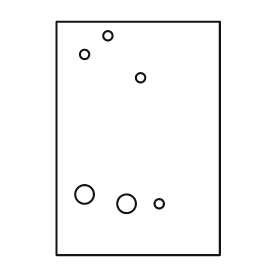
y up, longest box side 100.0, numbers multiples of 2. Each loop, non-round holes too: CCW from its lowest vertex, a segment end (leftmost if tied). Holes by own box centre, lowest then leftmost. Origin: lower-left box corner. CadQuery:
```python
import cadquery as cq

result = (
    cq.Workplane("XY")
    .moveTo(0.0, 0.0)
    .lineTo(70.0, 0.0)
    .lineTo(70.0, 100.0)
    .lineTo(0.0, 100.0)
    .close()
    .moveTo(30.0, 22.0)
    .circle(4.0)
    .moveTo(44.0, 22.0)
    .circle(2.0)
    .moveTo(12.0, 26.0)
    .circle(4.0)
    .moveTo(36.0, 76.0)
    .circle(2.0)
    .moveTo(12.0, 86.0)
    .circle(2.0)
    .moveTo(22.0, 94.0)
    .circle(2.0)
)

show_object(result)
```